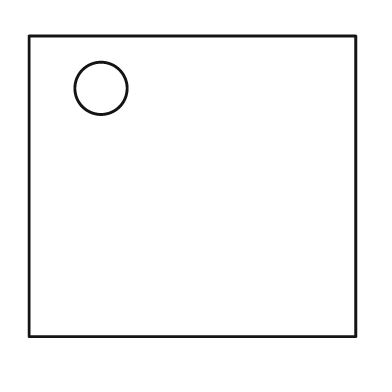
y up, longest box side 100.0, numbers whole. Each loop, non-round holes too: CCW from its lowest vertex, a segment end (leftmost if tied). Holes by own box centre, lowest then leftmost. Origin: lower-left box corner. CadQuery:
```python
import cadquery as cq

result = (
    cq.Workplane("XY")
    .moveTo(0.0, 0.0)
    .lineTo(100.0, 0.0)
    .lineTo(100.0, 92.0)
    .lineTo(0.0, 92.0)
    .close()
    .moveTo(22.0, 76.0)
    .circle(8.0)
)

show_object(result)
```